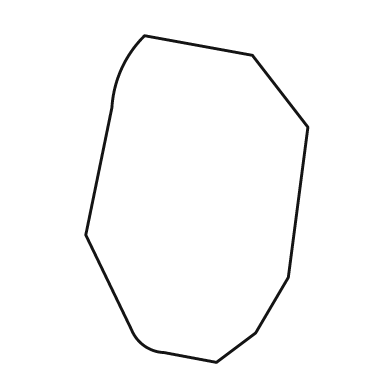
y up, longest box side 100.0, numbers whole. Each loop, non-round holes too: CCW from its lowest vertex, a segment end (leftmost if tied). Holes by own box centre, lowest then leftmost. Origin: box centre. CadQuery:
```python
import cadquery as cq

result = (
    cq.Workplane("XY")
    .moveTo(6.0, -50.0)
    .lineTo(18.0, -41.0)
    .lineTo(28.0, -24.0)
    .lineTo(34.0, 22.0)
    .lineTo(17.0, 44.0)
    .lineTo(-16.0, 50.0)
    .threePointArc((-23.0, 40.0), (-26.0, 28.0))
    .lineTo(-34.0, -11.0)
    .lineTo(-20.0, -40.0)
    .threePointArc((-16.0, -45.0), (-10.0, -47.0))
    .close()
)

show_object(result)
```